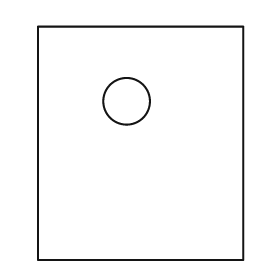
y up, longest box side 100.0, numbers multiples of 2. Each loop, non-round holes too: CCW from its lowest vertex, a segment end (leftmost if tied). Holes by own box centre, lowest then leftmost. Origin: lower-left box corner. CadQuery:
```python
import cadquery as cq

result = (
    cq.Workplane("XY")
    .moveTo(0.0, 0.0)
    .lineTo(88.0, 0.0)
    .lineTo(88.0, 100.0)
    .lineTo(0.0, 100.0)
    .close()
    .moveTo(38.0, 68.0)
    .circle(10.0)
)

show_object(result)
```